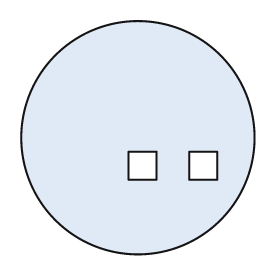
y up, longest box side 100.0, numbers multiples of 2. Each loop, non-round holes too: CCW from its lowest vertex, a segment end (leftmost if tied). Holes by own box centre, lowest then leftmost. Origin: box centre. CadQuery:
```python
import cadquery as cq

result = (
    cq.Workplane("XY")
    .moveTo(0.0, 0.0)
    .circle(50.0)
    .moveTo(-4.0, -18.0)
    .lineTo(8.0, -18.0)
    .lineTo(8.0, -6.0)
    .lineTo(-4.0, -6.0)
    .close()
    .moveTo(22.0, -18.0)
    .lineTo(34.0, -18.0)
    .lineTo(34.0, -6.0)
    .lineTo(22.0, -6.0)
    .close()
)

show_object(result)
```